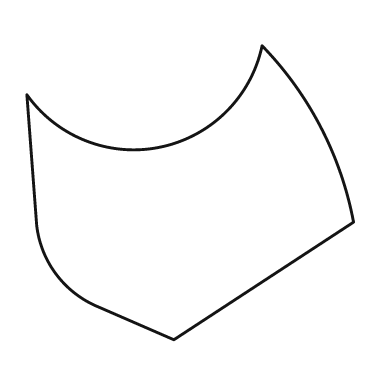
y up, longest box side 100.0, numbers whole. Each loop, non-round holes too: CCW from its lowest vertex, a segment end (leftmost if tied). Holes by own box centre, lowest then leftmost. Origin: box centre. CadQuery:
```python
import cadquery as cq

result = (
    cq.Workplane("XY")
    .moveTo(-5.0, -45.0)
    .lineTo(50.0, -9.0)
    .threePointArc((40.0, 20.0), (22.0, 45.0))
    .threePointArc((-9.0, 14.0), (-50.0, 30.0))
    .lineTo(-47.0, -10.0)
    .threePointArc((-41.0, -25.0), (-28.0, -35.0))
    .close()
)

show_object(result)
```